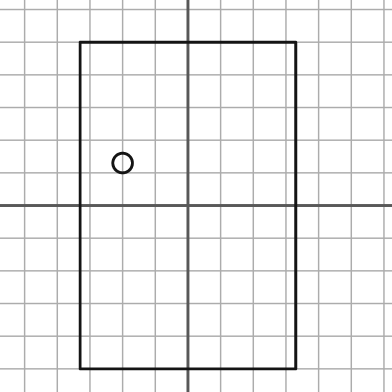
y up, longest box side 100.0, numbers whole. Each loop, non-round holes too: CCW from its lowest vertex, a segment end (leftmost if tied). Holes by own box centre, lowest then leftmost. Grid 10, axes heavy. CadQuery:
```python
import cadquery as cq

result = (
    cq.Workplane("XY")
    .moveTo(-33.0, -50.0)
    .lineTo(33.0, -50.0)
    .lineTo(33.0, 50.0)
    .lineTo(-33.0, 50.0)
    .close()
    .moveTo(-20.0, 13.0)
    .circle(3.0)
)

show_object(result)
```